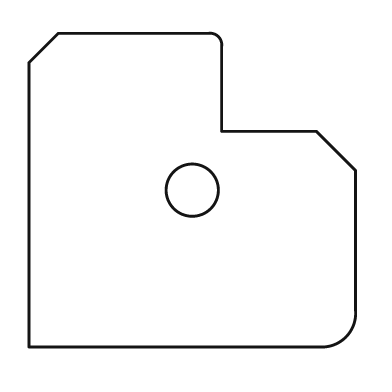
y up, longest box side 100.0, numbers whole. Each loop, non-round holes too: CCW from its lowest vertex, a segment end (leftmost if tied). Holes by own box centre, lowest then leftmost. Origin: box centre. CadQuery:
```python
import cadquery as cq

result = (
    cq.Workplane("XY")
    .moveTo(-50.0, -48.0)
    .lineTo(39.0, -48.0)
    .threePointArc((47.0, -45.0), (50.0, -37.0))
    .lineTo(50.0, 6.0)
    .lineTo(38.0, 18.0)
    .lineTo(9.0, 18.0)
    .lineTo(9.0, 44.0)
    .threePointArc((8.0, 47.0), (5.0, 48.0))
    .lineTo(-41.0, 48.0)
    .lineTo(-50.0, 39.0)
    .close()
    .moveTo(0.0, 0.0)
    .circle(8.0)
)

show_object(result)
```